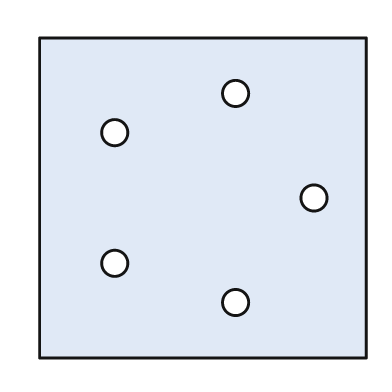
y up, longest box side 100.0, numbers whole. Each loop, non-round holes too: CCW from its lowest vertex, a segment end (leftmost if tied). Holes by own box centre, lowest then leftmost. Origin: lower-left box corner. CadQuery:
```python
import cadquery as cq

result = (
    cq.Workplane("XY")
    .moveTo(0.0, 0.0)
    .lineTo(100.0, 0.0)
    .lineTo(100.0, 98.0)
    .lineTo(0.0, 98.0)
    .close()
    .moveTo(60.0, 17.0)
    .circle(4.0)
    .moveTo(23.0, 29.0)
    .circle(4.0)
    .moveTo(84.0, 49.0)
    .circle(4.0)
    .moveTo(23.0, 69.0)
    .circle(4.0)
    .moveTo(60.0, 81.0)
    .circle(4.0)
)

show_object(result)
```